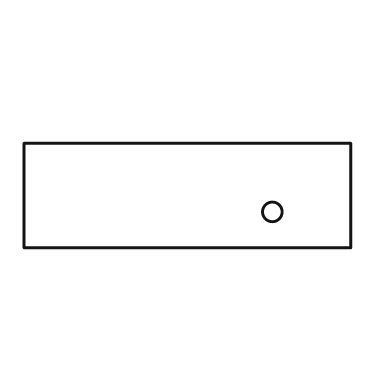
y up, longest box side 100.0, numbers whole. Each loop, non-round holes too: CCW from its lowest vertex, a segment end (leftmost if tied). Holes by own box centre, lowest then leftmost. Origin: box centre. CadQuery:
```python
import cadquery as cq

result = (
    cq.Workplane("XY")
    .moveTo(-50.0, -16.0)
    .lineTo(50.0, -16.0)
    .lineTo(50.0, 16.0)
    .lineTo(-50.0, 16.0)
    .close()
    .moveTo(26.0, -5.0)
    .circle(3.0)
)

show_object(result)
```